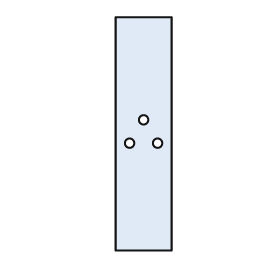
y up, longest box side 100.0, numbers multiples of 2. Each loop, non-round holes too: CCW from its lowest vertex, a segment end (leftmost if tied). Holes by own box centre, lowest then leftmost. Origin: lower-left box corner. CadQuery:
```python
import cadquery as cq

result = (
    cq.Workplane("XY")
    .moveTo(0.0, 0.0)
    .lineTo(24.0, 0.0)
    .lineTo(24.0, 100.0)
    .lineTo(0.0, 100.0)
    .close()
    .moveTo(6.0, 46.0)
    .circle(2.0)
    .moveTo(18.0, 46.0)
    .circle(2.0)
    .moveTo(12.0, 56.0)
    .circle(2.0)
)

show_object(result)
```